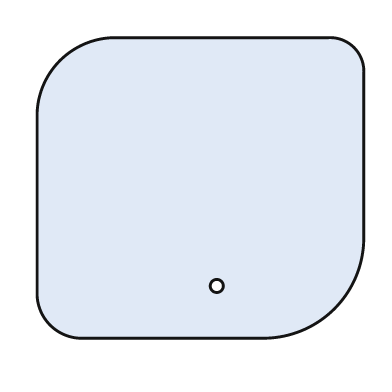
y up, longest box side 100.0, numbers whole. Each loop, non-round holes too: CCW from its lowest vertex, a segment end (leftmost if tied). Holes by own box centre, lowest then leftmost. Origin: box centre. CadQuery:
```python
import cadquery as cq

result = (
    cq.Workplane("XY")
    .moveTo(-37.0, -46.0)
    .lineTo(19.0, -46.0)
    .threePointArc((41.0, -37.0), (50.0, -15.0))
    .lineTo(50.0, 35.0)
    .threePointArc((47.0, 43.0), (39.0, 46.0))
    .lineTo(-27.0, 46.0)
    .threePointArc((-43.0, 39.0), (-50.0, 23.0))
    .lineTo(-50.0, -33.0)
    .threePointArc((-46.0, -42.0), (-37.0, -46.0))
    .close()
    .moveTo(5.0, -30.0)
    .circle(2.0)
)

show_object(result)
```